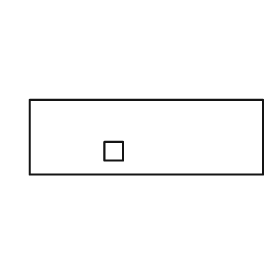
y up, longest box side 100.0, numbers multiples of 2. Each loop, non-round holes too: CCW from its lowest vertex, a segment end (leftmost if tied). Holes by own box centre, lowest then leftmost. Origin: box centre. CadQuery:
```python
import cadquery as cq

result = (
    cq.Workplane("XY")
    .moveTo(-50.0, -16.0)
    .lineTo(50.0, -16.0)
    .lineTo(50.0, 16.0)
    .lineTo(-50.0, 16.0)
    .close()
    .moveTo(-18.0, -10.0)
    .lineTo(-10.0, -10.0)
    .lineTo(-10.0, -2.0)
    .lineTo(-18.0, -2.0)
    .close()
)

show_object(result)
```